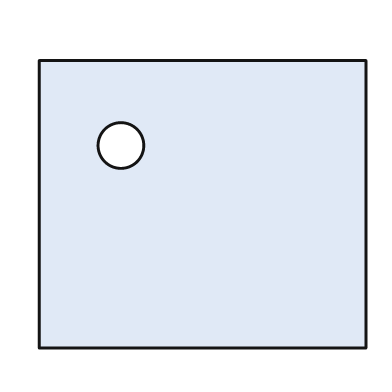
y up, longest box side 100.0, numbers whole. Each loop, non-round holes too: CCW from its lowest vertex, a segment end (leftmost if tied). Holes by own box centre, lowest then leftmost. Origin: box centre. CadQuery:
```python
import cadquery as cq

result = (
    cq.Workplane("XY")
    .moveTo(-50.0, -44.0)
    .lineTo(50.0, -44.0)
    .lineTo(50.0, 44.0)
    .lineTo(-50.0, 44.0)
    .close()
    .moveTo(-25.0, 18.0)
    .circle(7.0)
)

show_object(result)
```